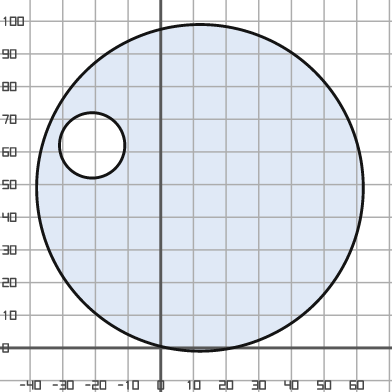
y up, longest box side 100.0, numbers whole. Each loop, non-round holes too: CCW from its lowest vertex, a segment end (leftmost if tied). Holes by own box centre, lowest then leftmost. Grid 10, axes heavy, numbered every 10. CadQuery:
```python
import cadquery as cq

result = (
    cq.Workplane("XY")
    .moveTo(12.0, 49.0)
    .circle(50.0)
    .moveTo(-21.0, 62.0)
    .circle(10.0)
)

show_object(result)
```